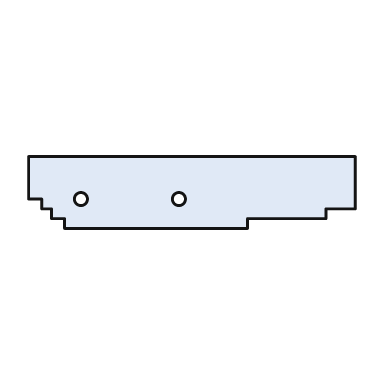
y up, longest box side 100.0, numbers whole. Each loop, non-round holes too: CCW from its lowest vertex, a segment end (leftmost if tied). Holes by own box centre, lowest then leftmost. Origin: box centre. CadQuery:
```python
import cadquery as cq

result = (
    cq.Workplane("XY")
    .moveTo(-39.0, -11.0)
    .lineTo(17.0, -11.0)
    .lineTo(17.0, -8.0)
    .lineTo(41.0, -8.0)
    .lineTo(41.0, -5.0)
    .lineTo(50.0, -5.0)
    .lineTo(50.0, 11.0)
    .lineTo(-50.0, 11.0)
    .lineTo(-50.0, -2.0)
    .lineTo(-46.0, -2.0)
    .lineTo(-46.0, -5.0)
    .lineTo(-43.0, -5.0)
    .lineTo(-43.0, -8.0)
    .lineTo(-39.0, -8.0)
    .close()
    .moveTo(-34.0, -2.0)
    .circle(2.0)
    .moveTo(-4.0, -2.0)
    .circle(2.0)
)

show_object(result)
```